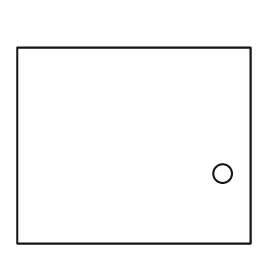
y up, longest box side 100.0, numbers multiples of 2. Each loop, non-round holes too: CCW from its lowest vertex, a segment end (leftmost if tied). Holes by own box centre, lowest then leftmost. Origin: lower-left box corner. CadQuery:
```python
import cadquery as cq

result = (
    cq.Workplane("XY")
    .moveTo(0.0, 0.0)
    .lineTo(100.0, 0.0)
    .lineTo(100.0, 84.0)
    .lineTo(0.0, 84.0)
    .close()
    .moveTo(88.0, 30.0)
    .circle(4.0)
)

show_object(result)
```